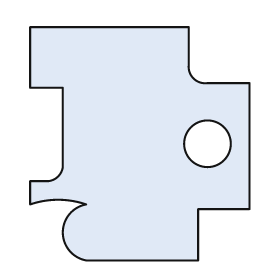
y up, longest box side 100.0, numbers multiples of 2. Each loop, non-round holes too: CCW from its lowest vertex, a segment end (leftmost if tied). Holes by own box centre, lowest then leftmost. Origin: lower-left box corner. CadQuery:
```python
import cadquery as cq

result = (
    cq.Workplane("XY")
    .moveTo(24.0, 0.0)
    .lineTo(72.0, 0.0)
    .lineTo(72.0, 22.0)
    .lineTo(94.0, 22.0)
    .lineTo(94.0, 76.0)
    .lineTo(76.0, 76.0)
    .threePointArc((70.0, 78.0), (68.0, 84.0))
    .lineTo(68.0, 100.0)
    .lineTo(0.0, 100.0)
    .lineTo(0.0, 74.0)
    .lineTo(14.0, 74.0)
    .lineTo(14.0, 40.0)
    .threePointArc((12.0, 36.0), (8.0, 34.0))
    .lineTo(0.0, 34.0)
    .lineTo(0.0, 24.0)
    .threePointArc((12.0, 26.0), (24.0, 24.0))
    .threePointArc((14.0, 12.0), (24.0, 0.0))
    .close()
    .moveTo(76.0, 50.0)
    .circle(10.0)
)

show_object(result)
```